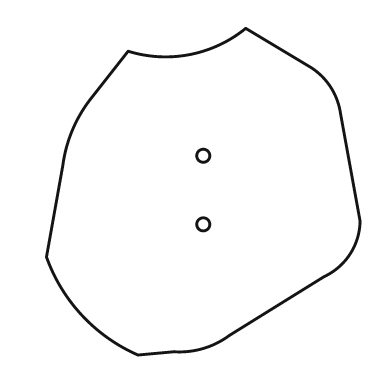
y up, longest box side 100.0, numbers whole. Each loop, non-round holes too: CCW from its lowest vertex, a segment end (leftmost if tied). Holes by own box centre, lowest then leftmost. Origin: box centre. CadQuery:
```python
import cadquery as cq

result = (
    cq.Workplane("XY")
    .moveTo(-20.0, -50.0)
    .lineTo(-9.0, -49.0)
    .threePointArc((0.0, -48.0), (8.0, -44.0))
    .lineTo(37.0, -26.0)
    .threePointArc((45.0, -19.0), (48.0, -9.0))
    .lineTo(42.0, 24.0)
    .threePointArc((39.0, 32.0), (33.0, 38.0))
    .lineTo(13.0, 50.0)
    .threePointArc((-4.0, 42.0), (-23.0, 43.0))
    .lineTo(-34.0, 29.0)
    .threePointArc((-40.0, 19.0), (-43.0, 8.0))
    .lineTo(-48.0, -20.0)
    .threePointArc((-37.0, -38.0), (-20.0, -50.0))
    .close()
    .moveTo(0.0, -10.0)
    .circle(2.0)
    .moveTo(0.0, 11.0)
    .circle(2.0)
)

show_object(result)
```